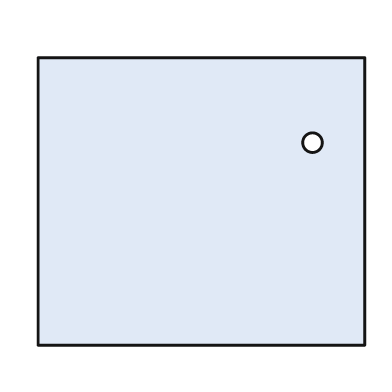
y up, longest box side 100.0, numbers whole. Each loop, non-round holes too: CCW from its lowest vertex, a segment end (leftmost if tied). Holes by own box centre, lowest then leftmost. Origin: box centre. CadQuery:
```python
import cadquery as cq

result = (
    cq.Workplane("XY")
    .moveTo(-50.0, -44.0)
    .lineTo(50.0, -44.0)
    .lineTo(50.0, 44.0)
    .lineTo(-50.0, 44.0)
    .close()
    .moveTo(34.0, 18.0)
    .circle(3.0)
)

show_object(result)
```